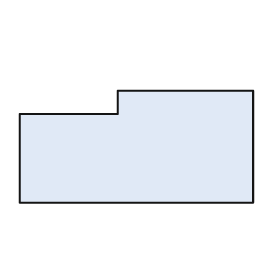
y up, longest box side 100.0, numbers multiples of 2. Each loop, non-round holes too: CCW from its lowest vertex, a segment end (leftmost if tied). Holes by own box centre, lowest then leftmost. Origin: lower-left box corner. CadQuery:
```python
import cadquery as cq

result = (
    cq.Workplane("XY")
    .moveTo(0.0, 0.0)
    .lineTo(100.0, 0.0)
    .lineTo(100.0, 48.0)
    .lineTo(42.0, 48.0)
    .lineTo(42.0, 38.0)
    .lineTo(0.0, 38.0)
    .close()
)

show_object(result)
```